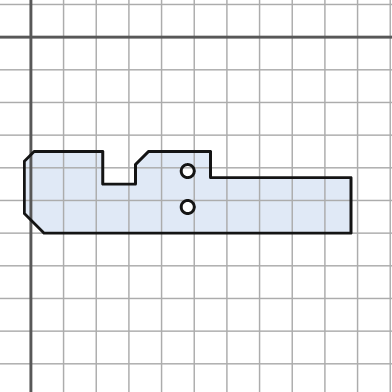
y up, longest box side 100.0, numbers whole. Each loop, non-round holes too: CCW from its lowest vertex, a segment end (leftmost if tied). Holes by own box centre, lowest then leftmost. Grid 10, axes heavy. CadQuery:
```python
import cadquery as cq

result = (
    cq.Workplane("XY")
    .moveTo(4.0, -60.0)
    .lineTo(98.0, -60.0)
    .lineTo(98.0, -43.0)
    .lineTo(55.0, -43.0)
    .lineTo(55.0, -35.0)
    .lineTo(36.0, -35.0)
    .lineTo(32.0, -39.0)
    .lineTo(32.0, -45.0)
    .lineTo(22.0, -45.0)
    .lineTo(22.0, -35.0)
    .lineTo(1.0, -35.0)
    .lineTo(-2.0, -38.0)
    .lineTo(-2.0, -54.0)
    .close()
    .moveTo(48.0, -52.0)
    .circle(2.0)
    .moveTo(48.0, -41.0)
    .circle(2.0)
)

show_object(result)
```